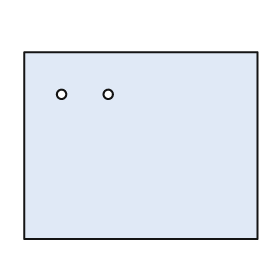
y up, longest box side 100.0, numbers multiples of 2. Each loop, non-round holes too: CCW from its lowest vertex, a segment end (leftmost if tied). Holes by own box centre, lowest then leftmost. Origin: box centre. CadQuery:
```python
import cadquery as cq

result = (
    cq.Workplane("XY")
    .moveTo(-50.0, -40.0)
    .lineTo(50.0, -40.0)
    .lineTo(50.0, 40.0)
    .lineTo(-50.0, 40.0)
    .close()
    .moveTo(-34.0, 22.0)
    .circle(2.0)
    .moveTo(-14.0, 22.0)
    .circle(2.0)
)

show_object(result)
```